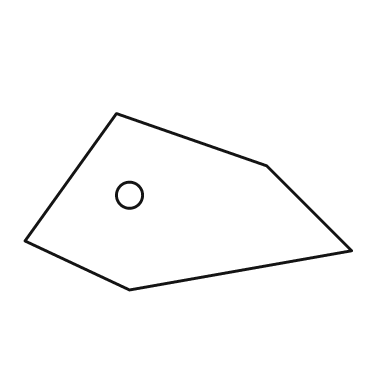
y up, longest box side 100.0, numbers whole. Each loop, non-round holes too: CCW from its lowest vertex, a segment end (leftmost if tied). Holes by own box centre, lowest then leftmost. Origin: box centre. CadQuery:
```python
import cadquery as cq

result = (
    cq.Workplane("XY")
    .moveTo(-18.0, -27.0)
    .lineTo(50.0, -15.0)
    .lineTo(24.0, 11.0)
    .lineTo(-22.0, 27.0)
    .lineTo(-50.0, -12.0)
    .close()
    .moveTo(-18.0, 2.0)
    .circle(4.0)
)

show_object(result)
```